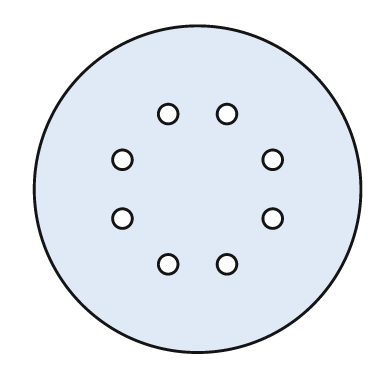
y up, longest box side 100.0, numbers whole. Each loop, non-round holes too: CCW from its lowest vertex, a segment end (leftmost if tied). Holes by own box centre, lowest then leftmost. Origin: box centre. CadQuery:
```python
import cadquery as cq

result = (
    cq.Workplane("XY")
    .moveTo(0.0, 0.0)
    .circle(50.0)
    .moveTo(-9.0, -23.0)
    .circle(3.0)
    .moveTo(9.0, -23.0)
    .circle(3.0)
    .moveTo(-23.0, -9.0)
    .circle(3.0)
    .moveTo(23.0, -9.0)
    .circle(3.0)
    .moveTo(-23.0, 9.0)
    .circle(3.0)
    .moveTo(23.0, 9.0)
    .circle(3.0)
    .moveTo(-9.0, 23.0)
    .circle(3.0)
    .moveTo(9.0, 23.0)
    .circle(3.0)
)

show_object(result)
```